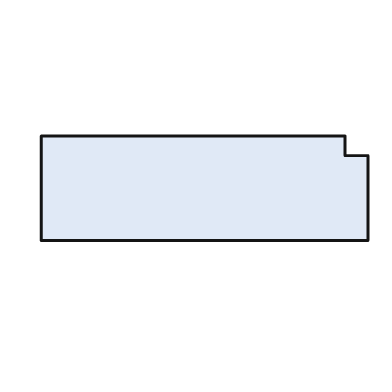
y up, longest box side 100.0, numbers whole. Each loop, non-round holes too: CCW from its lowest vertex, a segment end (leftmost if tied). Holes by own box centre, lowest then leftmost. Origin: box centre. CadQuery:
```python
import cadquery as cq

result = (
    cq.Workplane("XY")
    .moveTo(-50.0, -16.0)
    .lineTo(50.0, -16.0)
    .lineTo(50.0, 10.0)
    .lineTo(43.0, 10.0)
    .lineTo(43.0, 16.0)
    .lineTo(-50.0, 16.0)
    .close()
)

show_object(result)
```